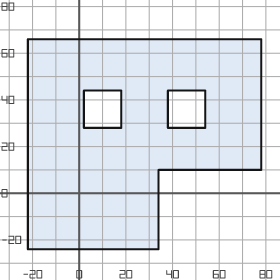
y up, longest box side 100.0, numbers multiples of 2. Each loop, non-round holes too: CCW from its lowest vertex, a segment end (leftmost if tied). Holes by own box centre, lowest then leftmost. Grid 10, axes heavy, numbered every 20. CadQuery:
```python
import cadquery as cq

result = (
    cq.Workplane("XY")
    .moveTo(-22.0, -24.0)
    .lineTo(34.0, -24.0)
    .lineTo(34.0, 10.0)
    .lineTo(78.0, 10.0)
    .lineTo(78.0, 66.0)
    .lineTo(-22.0, 66.0)
    .close()
    .moveTo(2.0, 28.0)
    .lineTo(18.0, 28.0)
    .lineTo(18.0, 44.0)
    .lineTo(2.0, 44.0)
    .close()
    .moveTo(38.0, 28.0)
    .lineTo(54.0, 28.0)
    .lineTo(54.0, 44.0)
    .lineTo(38.0, 44.0)
    .close()
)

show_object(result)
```